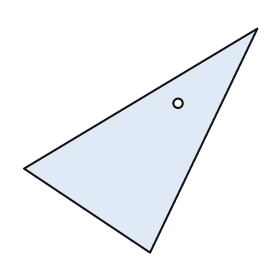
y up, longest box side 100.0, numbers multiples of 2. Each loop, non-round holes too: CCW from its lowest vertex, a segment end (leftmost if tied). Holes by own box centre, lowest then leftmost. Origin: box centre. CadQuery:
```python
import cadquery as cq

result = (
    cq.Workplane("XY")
    .moveTo(4.0, -48.0)
    .lineTo(50.0, 48.0)
    .lineTo(-50.0, -12.0)
    .close()
    .moveTo(16.0, 16.0)
    .circle(2.0)
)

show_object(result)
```